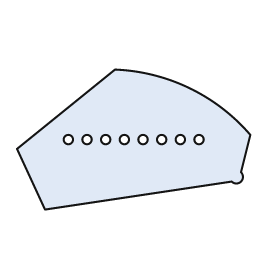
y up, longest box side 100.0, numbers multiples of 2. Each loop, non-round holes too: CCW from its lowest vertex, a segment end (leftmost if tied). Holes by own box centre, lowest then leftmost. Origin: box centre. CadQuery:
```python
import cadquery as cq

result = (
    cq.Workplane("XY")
    .moveTo(-38.0, -30.0)
    .lineTo(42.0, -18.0)
    .threePointArc((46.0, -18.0), (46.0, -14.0))
    .lineTo(50.0, 2.0)
    .threePointArc((24.0, 22.0), (-8.0, 30.0))
    .lineTo(-50.0, -4.0)
    .close()
    .moveTo(-28.0, 0.0)
    .circle(2.0)
    .moveTo(-20.0, 0.0)
    .circle(2.0)
    .moveTo(-12.0, 0.0)
    .circle(2.0)
    .moveTo(-4.0, 0.0)
    .circle(2.0)
    .moveTo(4.0, 0.0)
    .circle(2.0)
    .moveTo(12.0, 0.0)
    .circle(2.0)
    .moveTo(20.0, 0.0)
    .circle(2.0)
    .moveTo(28.0, 0.0)
    .circle(2.0)
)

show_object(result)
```